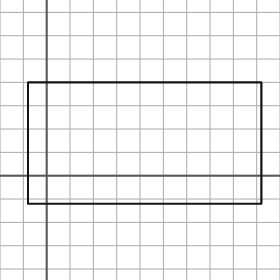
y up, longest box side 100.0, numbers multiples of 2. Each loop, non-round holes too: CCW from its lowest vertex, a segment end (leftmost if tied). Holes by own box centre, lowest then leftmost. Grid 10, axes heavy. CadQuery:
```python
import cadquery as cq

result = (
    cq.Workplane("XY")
    .moveTo(-8.0, -12.0)
    .lineTo(92.0, -12.0)
    .lineTo(92.0, 40.0)
    .lineTo(-8.0, 40.0)
    .close()
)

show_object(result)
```